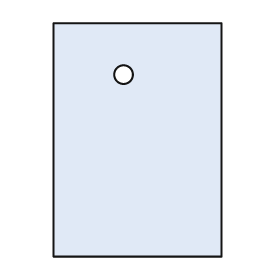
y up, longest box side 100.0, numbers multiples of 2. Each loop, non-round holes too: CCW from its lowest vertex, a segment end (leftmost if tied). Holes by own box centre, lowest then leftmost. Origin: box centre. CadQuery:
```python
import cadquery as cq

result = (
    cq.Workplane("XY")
    .moveTo(-36.0, -50.0)
    .lineTo(36.0, -50.0)
    .lineTo(36.0, 50.0)
    .lineTo(-36.0, 50.0)
    .close()
    .moveTo(-6.0, 28.0)
    .circle(4.0)
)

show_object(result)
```